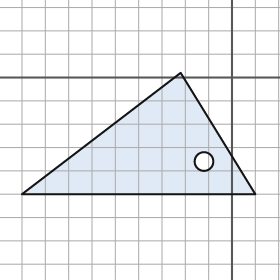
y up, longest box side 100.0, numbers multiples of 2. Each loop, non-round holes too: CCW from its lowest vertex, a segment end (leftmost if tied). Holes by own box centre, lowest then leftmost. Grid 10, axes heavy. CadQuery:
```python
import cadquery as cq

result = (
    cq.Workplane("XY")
    .moveTo(-90.0, -50.0)
    .lineTo(10.0, -50.0)
    .lineTo(-22.0, 2.0)
    .close()
    .moveTo(-12.0, -36.0)
    .circle(4.0)
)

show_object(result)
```